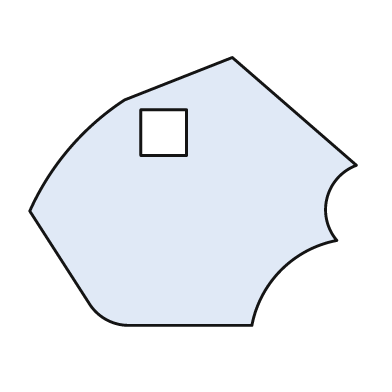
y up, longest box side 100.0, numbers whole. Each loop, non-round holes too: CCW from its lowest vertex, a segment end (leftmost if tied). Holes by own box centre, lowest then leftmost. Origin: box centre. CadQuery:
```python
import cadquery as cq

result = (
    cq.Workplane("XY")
    .moveTo(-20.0, -41.0)
    .lineTo(18.0, -41.0)
    .threePointArc((27.0, -24.0), (44.0, -15.0))
    .threePointArc((41.0, -2.0), (50.0, 8.0))
    .lineTo(12.0, 41.0)
    .lineTo(-21.0, 28.0)
    .threePointArc((-38.0, 13.0), (-50.0, -6.0))
    .lineTo(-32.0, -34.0)
    .threePointArc((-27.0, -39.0), (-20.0, -41.0))
    .close()
    .moveTo(-16.0, 11.0)
    .lineTo(-2.0, 11.0)
    .lineTo(-2.0, 25.0)
    .lineTo(-16.0, 25.0)
    .close()
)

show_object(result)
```